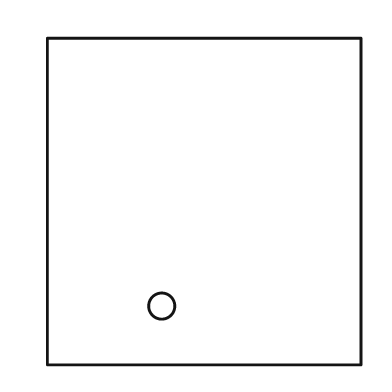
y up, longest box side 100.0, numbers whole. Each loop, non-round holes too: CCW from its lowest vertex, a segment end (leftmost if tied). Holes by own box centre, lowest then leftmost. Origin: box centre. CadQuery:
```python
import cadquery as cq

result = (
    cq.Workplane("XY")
    .moveTo(-48.0, -50.0)
    .lineTo(48.0, -50.0)
    .lineTo(48.0, 50.0)
    .lineTo(-48.0, 50.0)
    .close()
    .moveTo(-13.0, -32.0)
    .circle(4.0)
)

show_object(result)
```